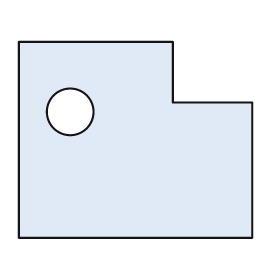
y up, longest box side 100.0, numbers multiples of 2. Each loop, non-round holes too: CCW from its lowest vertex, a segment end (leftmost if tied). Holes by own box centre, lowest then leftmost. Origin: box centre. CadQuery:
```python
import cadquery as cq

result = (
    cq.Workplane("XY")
    .moveTo(-50.0, -42.0)
    .lineTo(50.0, -42.0)
    .lineTo(50.0, 16.0)
    .lineTo(16.0, 16.0)
    .lineTo(16.0, 42.0)
    .lineTo(-50.0, 42.0)
    .close()
    .moveTo(-28.0, 12.0)
    .circle(10.0)
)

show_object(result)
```